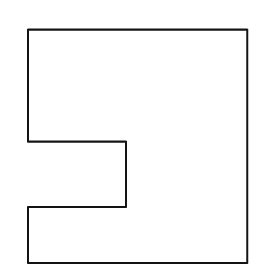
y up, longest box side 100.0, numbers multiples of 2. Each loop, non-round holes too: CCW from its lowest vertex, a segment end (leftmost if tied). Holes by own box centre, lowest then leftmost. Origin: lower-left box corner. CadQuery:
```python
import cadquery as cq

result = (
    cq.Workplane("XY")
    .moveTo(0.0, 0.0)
    .lineTo(94.0, 0.0)
    .lineTo(94.0, 100.0)
    .lineTo(0.0, 100.0)
    .lineTo(0.0, 52.0)
    .lineTo(42.0, 52.0)
    .lineTo(42.0, 24.0)
    .lineTo(0.0, 24.0)
    .close()
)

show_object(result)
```